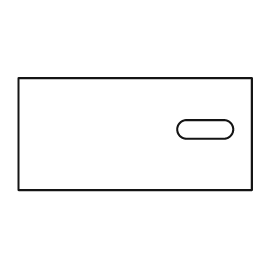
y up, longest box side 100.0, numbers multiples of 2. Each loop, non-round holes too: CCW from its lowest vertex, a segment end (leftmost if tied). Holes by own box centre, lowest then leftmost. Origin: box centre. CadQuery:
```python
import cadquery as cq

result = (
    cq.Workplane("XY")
    .moveTo(-50.0, -24.0)
    .lineTo(50.0, -24.0)
    .lineTo(50.0, 24.0)
    .lineTo(-50.0, 24.0)
    .close()
    .moveTo(22.0, -2.0)
    .lineTo(38.0, -2.0)
    .threePointArc((42.0, 2.0), (38.0, 6.0))
    .lineTo(22.0, 6.0)
    .threePointArc((18.0, 2.0), (22.0, -2.0))
    .close()
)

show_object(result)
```